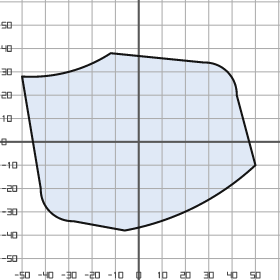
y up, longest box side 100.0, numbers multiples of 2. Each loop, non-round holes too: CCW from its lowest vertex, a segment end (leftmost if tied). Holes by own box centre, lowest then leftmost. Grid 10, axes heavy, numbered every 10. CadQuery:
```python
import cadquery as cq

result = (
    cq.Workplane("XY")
    .moveTo(-6.0, -38.0)
    .threePointArc((24.0, -28.0), (50.0, -10.0))
    .lineTo(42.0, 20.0)
    .threePointArc((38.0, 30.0), (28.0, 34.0))
    .lineTo(-12.0, 38.0)
    .threePointArc((-30.0, 30.0), (-50.0, 28.0))
    .lineTo(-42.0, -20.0)
    .threePointArc((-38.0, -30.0), (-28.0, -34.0))
    .close()
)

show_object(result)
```